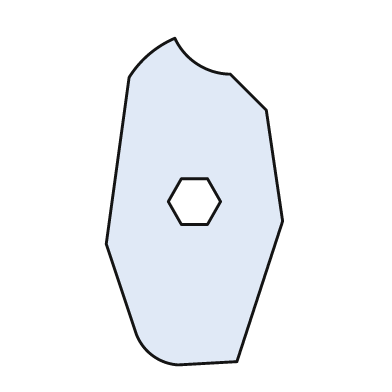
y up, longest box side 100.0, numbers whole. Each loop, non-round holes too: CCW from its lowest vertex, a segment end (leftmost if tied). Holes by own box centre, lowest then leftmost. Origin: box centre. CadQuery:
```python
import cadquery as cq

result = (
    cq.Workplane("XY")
    .moveTo(-5.0, -50.0)
    .lineTo(13.0, -49.0)
    .lineTo(27.0, -6.0)
    .lineTo(22.0, 28.0)
    .lineTo(11.0, 39.0)
    .threePointArc((1.0, 42.0), (-6.0, 50.0))
    .threePointArc((-14.0, 45.0), (-20.0, 38.0))
    .lineTo(-27.0, -13.0)
    .lineTo(-18.0, -40.0)
    .threePointArc((-13.0, -47.0), (-5.0, -50.0))
    .close()
    .moveTo(-4.0, -7.0)
    .lineTo(4.0, -7.0)
    .lineTo(8.0, 0.0)
    .lineTo(4.0, 7.0)
    .lineTo(-4.0, 7.0)
    .lineTo(-8.0, 0.0)
    .close()
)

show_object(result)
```